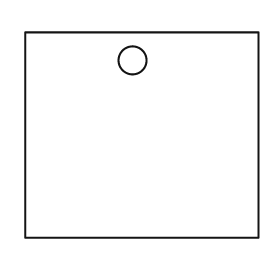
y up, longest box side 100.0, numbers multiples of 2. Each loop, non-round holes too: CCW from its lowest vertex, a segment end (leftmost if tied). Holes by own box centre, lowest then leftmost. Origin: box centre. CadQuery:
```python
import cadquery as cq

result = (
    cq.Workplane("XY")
    .moveTo(-50.0, -44.0)
    .lineTo(50.0, -44.0)
    .lineTo(50.0, 44.0)
    .lineTo(-50.0, 44.0)
    .close()
    .moveTo(-4.0, 32.0)
    .circle(6.0)
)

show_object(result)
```